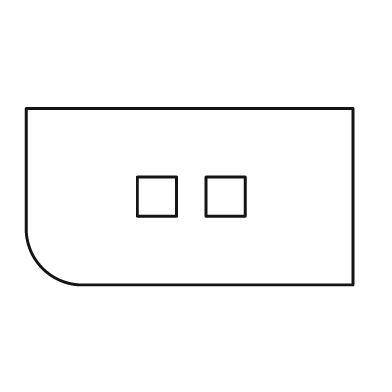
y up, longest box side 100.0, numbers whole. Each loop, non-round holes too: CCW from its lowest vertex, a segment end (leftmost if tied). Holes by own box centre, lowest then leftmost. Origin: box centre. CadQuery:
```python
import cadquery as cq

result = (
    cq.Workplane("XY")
    .moveTo(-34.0, -27.0)
    .lineTo(50.0, -27.0)
    .lineTo(50.0, 27.0)
    .lineTo(-50.0, 27.0)
    .lineTo(-50.0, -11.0)
    .threePointArc((-45.0, -22.0), (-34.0, -27.0))
    .close()
    .moveTo(-16.0, -6.0)
    .lineTo(-4.0, -6.0)
    .lineTo(-4.0, 6.0)
    .lineTo(-16.0, 6.0)
    .close()
    .moveTo(5.0, -6.0)
    .lineTo(17.0, -6.0)
    .lineTo(17.0, 6.0)
    .lineTo(5.0, 6.0)
    .close()
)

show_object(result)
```